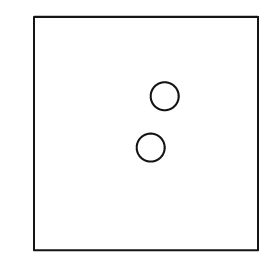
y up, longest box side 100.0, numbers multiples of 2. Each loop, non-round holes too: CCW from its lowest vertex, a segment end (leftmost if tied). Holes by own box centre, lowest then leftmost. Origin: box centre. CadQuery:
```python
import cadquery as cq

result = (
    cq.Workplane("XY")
    .moveTo(-48.0, -50.0)
    .lineTo(48.0, -50.0)
    .lineTo(48.0, 50.0)
    .lineTo(-48.0, 50.0)
    .close()
    .moveTo(2.0, -6.0)
    .circle(6.0)
    .moveTo(8.0, 16.0)
    .circle(6.0)
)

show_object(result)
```